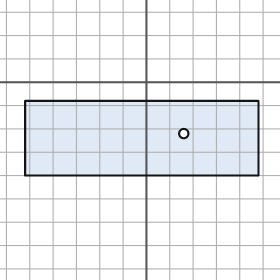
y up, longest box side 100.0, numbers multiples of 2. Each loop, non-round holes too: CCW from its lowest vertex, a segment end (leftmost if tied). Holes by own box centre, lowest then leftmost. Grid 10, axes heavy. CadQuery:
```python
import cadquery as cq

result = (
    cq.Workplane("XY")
    .moveTo(-52.0, -40.0)
    .lineTo(48.0, -40.0)
    .lineTo(48.0, -8.0)
    .lineTo(-52.0, -8.0)
    .close()
    .moveTo(16.0, -22.0)
    .circle(2.0)
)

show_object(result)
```